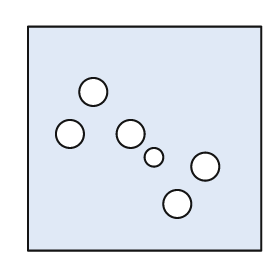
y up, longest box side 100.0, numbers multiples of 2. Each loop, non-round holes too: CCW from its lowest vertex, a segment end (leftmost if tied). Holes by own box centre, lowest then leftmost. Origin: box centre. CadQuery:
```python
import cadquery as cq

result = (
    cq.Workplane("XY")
    .moveTo(-50.0, -48.0)
    .lineTo(50.0, -48.0)
    .lineTo(50.0, 48.0)
    .lineTo(-50.0, 48.0)
    .close()
    .moveTo(14.0, -28.0)
    .circle(6.0)
    .moveTo(26.0, -12.0)
    .circle(6.0)
    .moveTo(4.0, -8.0)
    .circle(4.0)
    .moveTo(-32.0, 2.0)
    .circle(6.0)
    .moveTo(-6.0, 2.0)
    .circle(6.0)
    .moveTo(-22.0, 20.0)
    .circle(6.0)
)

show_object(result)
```